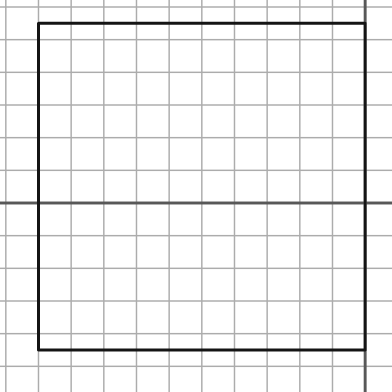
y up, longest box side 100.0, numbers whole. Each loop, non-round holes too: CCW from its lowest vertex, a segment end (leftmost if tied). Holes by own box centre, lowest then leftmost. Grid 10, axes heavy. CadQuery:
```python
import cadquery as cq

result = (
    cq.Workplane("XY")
    .moveTo(-100.0, -45.0)
    .lineTo(0.0, -45.0)
    .lineTo(0.0, 55.0)
    .lineTo(-100.0, 55.0)
    .close()
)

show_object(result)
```